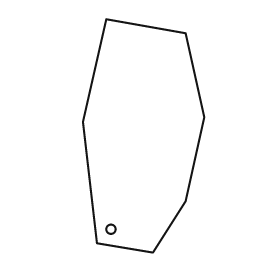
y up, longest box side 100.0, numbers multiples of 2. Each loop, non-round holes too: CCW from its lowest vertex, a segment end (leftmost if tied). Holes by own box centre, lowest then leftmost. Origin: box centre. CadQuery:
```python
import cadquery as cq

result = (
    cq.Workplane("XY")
    .moveTo(4.0, -50.0)
    .lineTo(18.0, -28.0)
    .lineTo(26.0, 8.0)
    .lineTo(18.0, 44.0)
    .lineTo(-16.0, 50.0)
    .lineTo(-26.0, 6.0)
    .lineTo(-20.0, -46.0)
    .close()
    .moveTo(-14.0, -40.0)
    .circle(2.0)
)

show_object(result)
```